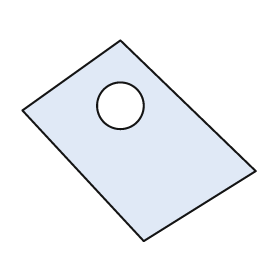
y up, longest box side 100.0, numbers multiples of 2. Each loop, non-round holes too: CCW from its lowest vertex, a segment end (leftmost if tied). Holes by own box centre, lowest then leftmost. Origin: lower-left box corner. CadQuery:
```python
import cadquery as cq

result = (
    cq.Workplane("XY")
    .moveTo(52.0, 0.0)
    .lineTo(100.0, 30.0)
    .lineTo(42.0, 86.0)
    .lineTo(0.0, 56.0)
    .close()
    .moveTo(42.0, 58.0)
    .circle(10.0)
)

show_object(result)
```